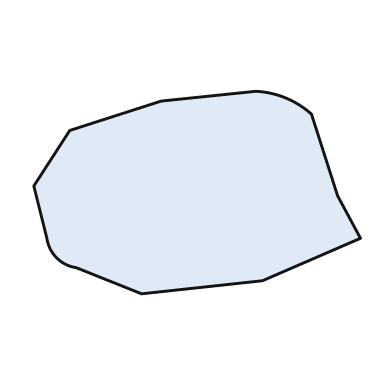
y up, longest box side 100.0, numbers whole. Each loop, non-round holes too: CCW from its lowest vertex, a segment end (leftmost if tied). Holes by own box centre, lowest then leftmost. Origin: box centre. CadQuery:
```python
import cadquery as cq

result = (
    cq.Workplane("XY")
    .moveTo(-17.0, -31.0)
    .lineTo(20.0, -27.0)
    .lineTo(50.0, -14.0)
    .lineTo(43.0, -1.0)
    .lineTo(35.0, 24.0)
    .threePointArc((27.0, 29.0), (18.0, 31.0))
    .lineTo(-11.0, 28.0)
    .lineTo(-39.0, 19.0)
    .lineTo(-50.0, 2.0)
    .lineTo(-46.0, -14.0)
    .threePointArc((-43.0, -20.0), (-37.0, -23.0))
    .close()
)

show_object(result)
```